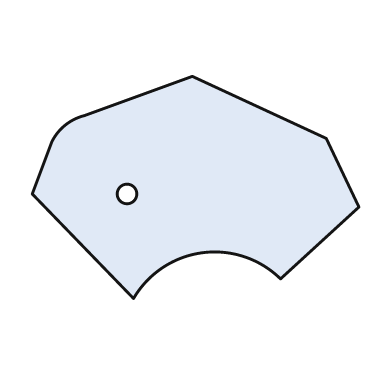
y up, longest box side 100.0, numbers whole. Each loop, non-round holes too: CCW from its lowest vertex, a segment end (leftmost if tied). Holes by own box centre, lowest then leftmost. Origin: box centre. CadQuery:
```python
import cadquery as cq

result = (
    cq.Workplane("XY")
    .moveTo(-19.0, -34.0)
    .threePointArc((2.0, -20.0), (26.0, -28.0))
    .lineTo(50.0, -6.0)
    .lineTo(40.0, 15.0)
    .lineTo(-1.0, 34.0)
    .lineTo(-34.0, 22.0)
    .threePointArc((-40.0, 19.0), (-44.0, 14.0))
    .lineTo(-50.0, -2.0)
    .close()
    .moveTo(-21.0, -2.0)
    .circle(3.0)
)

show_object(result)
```